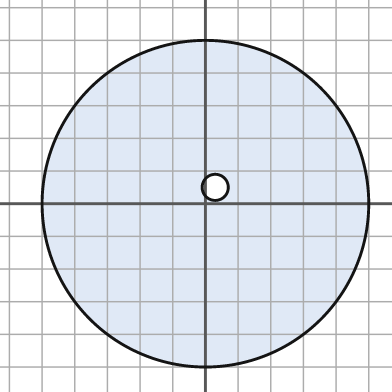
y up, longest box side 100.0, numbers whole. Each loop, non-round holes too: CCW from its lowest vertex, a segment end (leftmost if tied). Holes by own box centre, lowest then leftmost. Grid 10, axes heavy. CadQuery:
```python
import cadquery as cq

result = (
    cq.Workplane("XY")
    .moveTo(0.0, 0.0)
    .circle(50.0)
    .moveTo(3.0, 5.0)
    .circle(4.0)
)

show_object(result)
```